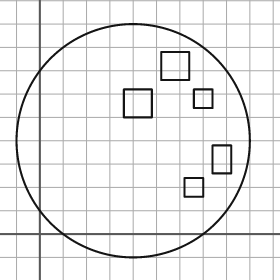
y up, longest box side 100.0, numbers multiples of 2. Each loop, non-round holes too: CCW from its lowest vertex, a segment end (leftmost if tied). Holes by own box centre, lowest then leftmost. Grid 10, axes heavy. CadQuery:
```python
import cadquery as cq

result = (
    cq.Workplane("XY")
    .moveTo(40.0, 40.0)
    .circle(50.0)
    .moveTo(62.0, 16.0)
    .lineTo(70.0, 16.0)
    .lineTo(70.0, 24.0)
    .lineTo(62.0, 24.0)
    .close()
    .moveTo(74.0, 26.0)
    .lineTo(82.0, 26.0)
    .lineTo(82.0, 38.0)
    .lineTo(74.0, 38.0)
    .close()
    .moveTo(36.0, 50.0)
    .lineTo(48.0, 50.0)
    .lineTo(48.0, 62.0)
    .lineTo(36.0, 62.0)
    .close()
    .moveTo(66.0, 54.0)
    .lineTo(74.0, 54.0)
    .lineTo(74.0, 62.0)
    .lineTo(66.0, 62.0)
    .close()
    .moveTo(52.0, 66.0)
    .lineTo(64.0, 66.0)
    .lineTo(64.0, 78.0)
    .lineTo(52.0, 78.0)
    .close()
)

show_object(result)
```